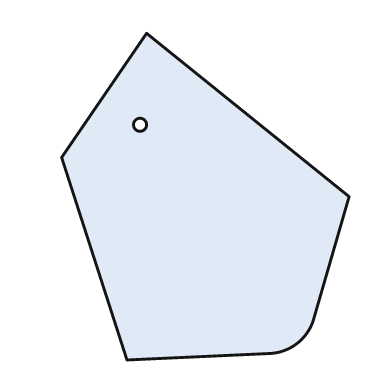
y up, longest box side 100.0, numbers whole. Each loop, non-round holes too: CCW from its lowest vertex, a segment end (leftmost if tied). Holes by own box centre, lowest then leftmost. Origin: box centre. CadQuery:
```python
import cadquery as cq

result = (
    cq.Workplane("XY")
    .moveTo(-24.0, -50.0)
    .lineTo(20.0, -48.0)
    .threePointArc((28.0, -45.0), (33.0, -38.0))
    .lineTo(44.0, 0.0)
    .lineTo(-18.0, 50.0)
    .lineTo(-44.0, 12.0)
    .close()
    .moveTo(-20.0, 22.0)
    .circle(2.0)
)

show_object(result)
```